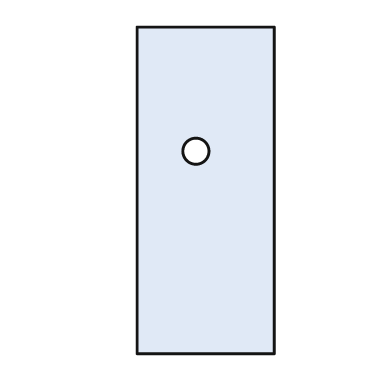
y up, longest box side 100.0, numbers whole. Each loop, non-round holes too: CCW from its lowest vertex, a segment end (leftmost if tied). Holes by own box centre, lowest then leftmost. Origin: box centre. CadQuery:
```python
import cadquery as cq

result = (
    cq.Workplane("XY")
    .moveTo(-21.0, -50.0)
    .lineTo(21.0, -50.0)
    .lineTo(21.0, 50.0)
    .lineTo(-21.0, 50.0)
    .close()
    .moveTo(-3.0, 12.0)
    .circle(4.0)
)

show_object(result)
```